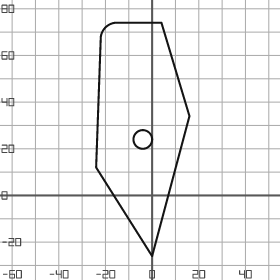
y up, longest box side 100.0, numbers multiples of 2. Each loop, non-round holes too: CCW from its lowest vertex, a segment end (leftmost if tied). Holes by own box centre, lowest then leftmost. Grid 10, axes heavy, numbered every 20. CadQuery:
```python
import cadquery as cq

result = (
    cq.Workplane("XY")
    .moveTo(0.0, -26.0)
    .lineTo(16.0, 34.0)
    .lineTo(4.0, 74.0)
    .lineTo(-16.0, 74.0)
    .threePointArc((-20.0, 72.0), (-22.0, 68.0))
    .lineTo(-24.0, 12.0)
    .close()
    .moveTo(-4.0, 24.0)
    .circle(4.0)
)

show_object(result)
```